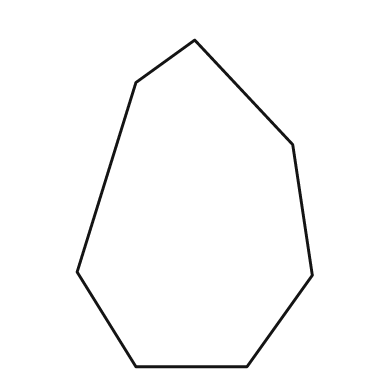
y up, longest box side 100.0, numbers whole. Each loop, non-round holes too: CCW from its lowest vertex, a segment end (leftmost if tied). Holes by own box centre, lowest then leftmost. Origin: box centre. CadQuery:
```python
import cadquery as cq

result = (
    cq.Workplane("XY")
    .moveTo(-18.0, -50.0)
    .lineTo(16.0, -50.0)
    .lineTo(36.0, -22.0)
    .lineTo(30.0, 18.0)
    .lineTo(0.0, 50.0)
    .lineTo(-18.0, 37.0)
    .lineTo(-36.0, -21.0)
    .close()
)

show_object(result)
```